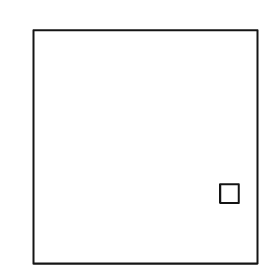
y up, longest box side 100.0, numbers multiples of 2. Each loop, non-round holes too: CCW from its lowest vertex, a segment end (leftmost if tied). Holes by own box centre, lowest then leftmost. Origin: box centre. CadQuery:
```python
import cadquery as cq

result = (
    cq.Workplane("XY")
    .moveTo(-48.0, -50.0)
    .lineTo(48.0, -50.0)
    .lineTo(48.0, 50.0)
    .lineTo(-48.0, 50.0)
    .close()
    .moveTo(32.0, -24.0)
    .lineTo(40.0, -24.0)
    .lineTo(40.0, -16.0)
    .lineTo(32.0, -16.0)
    .close()
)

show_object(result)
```